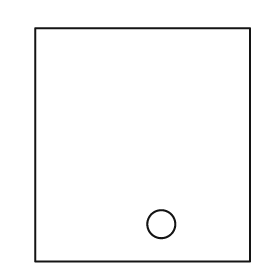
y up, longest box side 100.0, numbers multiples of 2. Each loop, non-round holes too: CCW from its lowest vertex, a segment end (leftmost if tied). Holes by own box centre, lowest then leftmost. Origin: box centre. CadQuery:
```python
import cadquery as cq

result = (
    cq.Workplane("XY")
    .moveTo(-46.0, -50.0)
    .lineTo(46.0, -50.0)
    .lineTo(46.0, 50.0)
    .lineTo(-46.0, 50.0)
    .close()
    .moveTo(8.0, -34.0)
    .circle(6.0)
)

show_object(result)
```